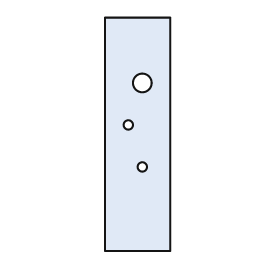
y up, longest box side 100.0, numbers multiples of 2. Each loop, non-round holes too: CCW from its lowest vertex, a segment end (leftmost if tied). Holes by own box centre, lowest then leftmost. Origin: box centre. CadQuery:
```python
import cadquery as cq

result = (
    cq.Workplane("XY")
    .moveTo(-14.0, -50.0)
    .lineTo(14.0, -50.0)
    .lineTo(14.0, 50.0)
    .lineTo(-14.0, 50.0)
    .close()
    .moveTo(2.0, -14.0)
    .circle(2.0)
    .moveTo(-4.0, 4.0)
    .circle(2.0)
    .moveTo(2.0, 22.0)
    .circle(4.0)
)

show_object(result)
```